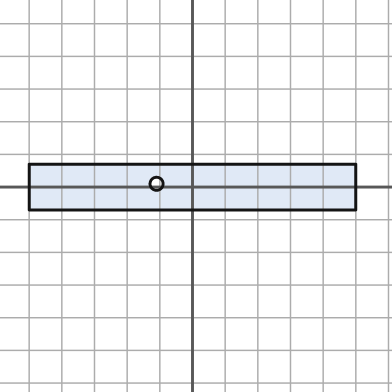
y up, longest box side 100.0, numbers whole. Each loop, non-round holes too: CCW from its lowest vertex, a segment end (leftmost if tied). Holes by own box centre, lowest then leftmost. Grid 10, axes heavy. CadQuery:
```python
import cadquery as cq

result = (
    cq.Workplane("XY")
    .moveTo(-50.0, -7.0)
    .lineTo(50.0, -7.0)
    .lineTo(50.0, 7.0)
    .lineTo(-50.0, 7.0)
    .close()
    .moveTo(-11.0, 1.0)
    .circle(2.0)
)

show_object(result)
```